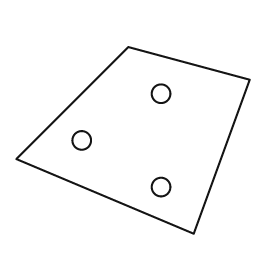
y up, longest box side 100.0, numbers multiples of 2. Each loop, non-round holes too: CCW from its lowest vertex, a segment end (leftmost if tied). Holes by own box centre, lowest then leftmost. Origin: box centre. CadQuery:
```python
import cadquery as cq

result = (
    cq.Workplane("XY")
    .moveTo(26.0, -40.0)
    .lineTo(50.0, 26.0)
    .lineTo(-2.0, 40.0)
    .lineTo(-50.0, -8.0)
    .close()
    .moveTo(12.0, -20.0)
    .circle(4.0)
    .moveTo(-22.0, 0.0)
    .circle(4.0)
    .moveTo(12.0, 20.0)
    .circle(4.0)
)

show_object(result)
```